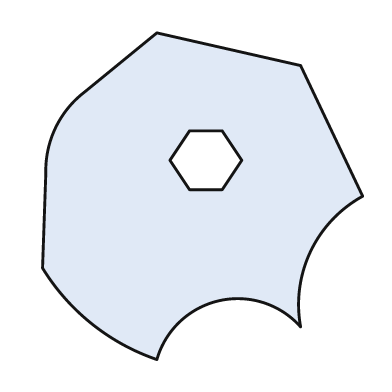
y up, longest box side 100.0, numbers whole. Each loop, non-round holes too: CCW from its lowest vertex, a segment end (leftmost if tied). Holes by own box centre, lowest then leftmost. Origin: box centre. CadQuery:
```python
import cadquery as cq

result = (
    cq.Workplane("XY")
    .moveTo(-14.0, -50.0)
    .threePointArc((5.0, -32.0), (30.0, -40.0))
    .threePointArc((33.0, -17.0), (49.0, 0.0))
    .lineTo(30.0, 40.0)
    .lineTo(-14.0, 50.0)
    .lineTo(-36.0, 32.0)
    .threePointArc((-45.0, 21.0), (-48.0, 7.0))
    .lineTo(-49.0, -22.0)
    .threePointArc((-34.0, -39.0), (-14.0, -50.0))
    .close()
    .moveTo(-4.0, 2.0)
    .lineTo(6.0, 2.0)
    .lineTo(12.0, 11.0)
    .lineTo(6.0, 20.0)
    .lineTo(-4.0, 20.0)
    .lineTo(-10.0, 11.0)
    .close()
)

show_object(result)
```